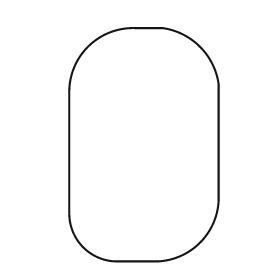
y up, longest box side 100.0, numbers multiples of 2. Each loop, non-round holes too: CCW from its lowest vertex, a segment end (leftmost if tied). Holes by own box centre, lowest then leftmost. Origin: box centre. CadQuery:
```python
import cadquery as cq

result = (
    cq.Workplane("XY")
    .moveTo(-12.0, -50.0)
    .lineTo(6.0, -50.0)
    .threePointArc((24.0, -42.0), (32.0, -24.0))
    .lineTo(32.0, 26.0)
    .threePointArc((24.0, 42.0), (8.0, 50.0))
    .lineTo(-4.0, 50.0)
    .threePointArc((-24.0, 42.0), (-32.0, 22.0))
    .lineTo(-32.0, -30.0)
    .threePointArc((-26.0, -44.0), (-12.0, -50.0))
    .close()
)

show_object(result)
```